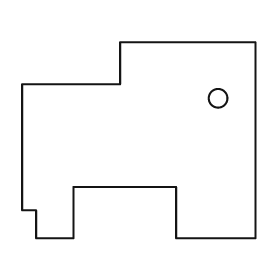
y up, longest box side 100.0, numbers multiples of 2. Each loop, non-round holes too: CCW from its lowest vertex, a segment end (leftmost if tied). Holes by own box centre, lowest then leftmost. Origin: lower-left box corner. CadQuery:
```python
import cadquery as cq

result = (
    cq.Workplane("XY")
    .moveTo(6.0, 0.0)
    .lineTo(22.0, 0.0)
    .lineTo(22.0, 22.0)
    .lineTo(66.0, 22.0)
    .lineTo(66.0, 0.0)
    .lineTo(100.0, 0.0)
    .lineTo(100.0, 84.0)
    .lineTo(42.0, 84.0)
    .lineTo(42.0, 66.0)
    .lineTo(0.0, 66.0)
    .lineTo(0.0, 12.0)
    .lineTo(6.0, 12.0)
    .close()
    .moveTo(84.0, 60.0)
    .circle(4.0)
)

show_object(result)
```